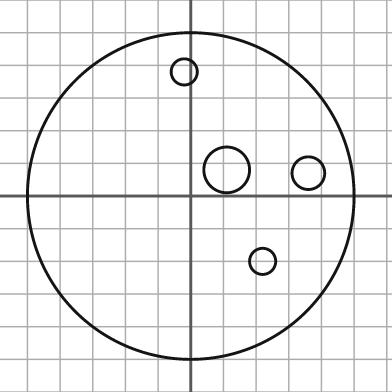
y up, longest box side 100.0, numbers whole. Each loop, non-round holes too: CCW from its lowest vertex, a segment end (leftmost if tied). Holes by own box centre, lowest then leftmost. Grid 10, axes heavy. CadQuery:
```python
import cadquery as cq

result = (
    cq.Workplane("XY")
    .moveTo(0.0, 0.0)
    .circle(50.0)
    .moveTo(22.0, -20.0)
    .circle(4.0)
    .moveTo(36.0, 7.0)
    .circle(5.0)
    .moveTo(11.0, 8.0)
    .circle(7.0)
    .moveTo(-2.0, 38.0)
    .circle(4.0)
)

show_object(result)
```